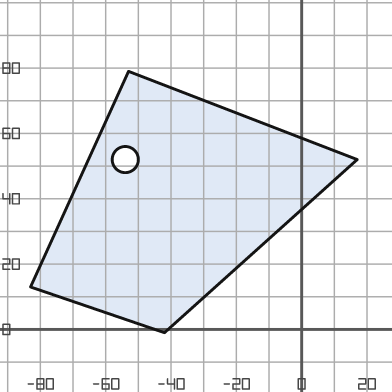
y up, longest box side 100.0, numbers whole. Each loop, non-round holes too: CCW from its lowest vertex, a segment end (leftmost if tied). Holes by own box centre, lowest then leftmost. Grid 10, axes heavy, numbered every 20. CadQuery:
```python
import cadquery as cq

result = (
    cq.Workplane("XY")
    .moveTo(-42.0, -1.0)
    .lineTo(17.0, 52.0)
    .lineTo(-53.0, 79.0)
    .lineTo(-83.0, 13.0)
    .close()
    .moveTo(-54.0, 52.0)
    .circle(4.0)
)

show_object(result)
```